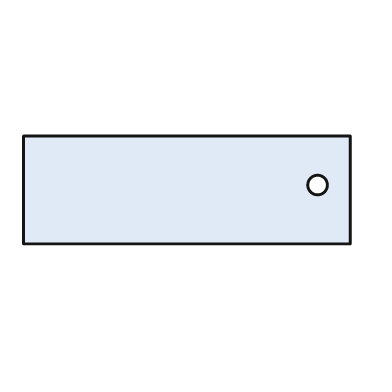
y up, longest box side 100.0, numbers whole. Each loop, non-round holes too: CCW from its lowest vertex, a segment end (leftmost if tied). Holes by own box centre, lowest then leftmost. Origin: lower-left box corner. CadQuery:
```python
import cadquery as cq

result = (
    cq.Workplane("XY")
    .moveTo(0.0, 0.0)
    .lineTo(100.0, 0.0)
    .lineTo(100.0, 33.0)
    .lineTo(0.0, 33.0)
    .close()
    .moveTo(90.0, 18.0)
    .circle(3.0)
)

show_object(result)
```